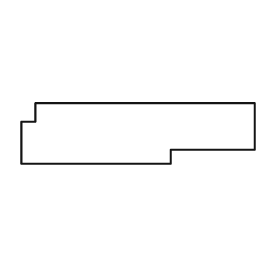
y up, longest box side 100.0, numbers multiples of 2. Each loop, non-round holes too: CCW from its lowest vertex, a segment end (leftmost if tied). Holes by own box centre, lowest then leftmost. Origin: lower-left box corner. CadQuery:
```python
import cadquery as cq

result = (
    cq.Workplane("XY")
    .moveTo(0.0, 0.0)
    .lineTo(64.0, 0.0)
    .lineTo(64.0, 6.0)
    .lineTo(100.0, 6.0)
    .lineTo(100.0, 26.0)
    .lineTo(6.0, 26.0)
    .lineTo(6.0, 18.0)
    .lineTo(0.0, 18.0)
    .close()
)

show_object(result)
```